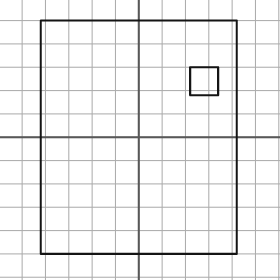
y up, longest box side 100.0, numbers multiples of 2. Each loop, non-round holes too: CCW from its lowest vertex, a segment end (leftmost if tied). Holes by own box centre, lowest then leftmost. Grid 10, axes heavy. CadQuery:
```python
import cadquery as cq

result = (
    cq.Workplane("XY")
    .moveTo(-42.0, -50.0)
    .lineTo(42.0, -50.0)
    .lineTo(42.0, 50.0)
    .lineTo(-42.0, 50.0)
    .close()
    .moveTo(22.0, 18.0)
    .lineTo(34.0, 18.0)
    .lineTo(34.0, 30.0)
    .lineTo(22.0, 30.0)
    .close()
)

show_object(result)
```